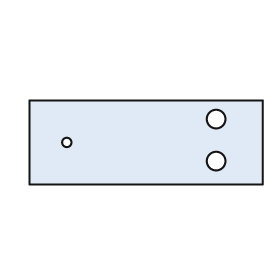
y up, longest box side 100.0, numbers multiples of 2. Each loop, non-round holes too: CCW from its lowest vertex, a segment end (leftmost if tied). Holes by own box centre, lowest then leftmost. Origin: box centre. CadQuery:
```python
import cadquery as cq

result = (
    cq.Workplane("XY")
    .moveTo(-50.0, -18.0)
    .lineTo(50.0, -18.0)
    .lineTo(50.0, 18.0)
    .lineTo(-50.0, 18.0)
    .close()
    .moveTo(30.0, -8.0)
    .circle(4.0)
    .moveTo(-34.0, 0.0)
    .circle(2.0)
    .moveTo(30.0, 10.0)
    .circle(4.0)
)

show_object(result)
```